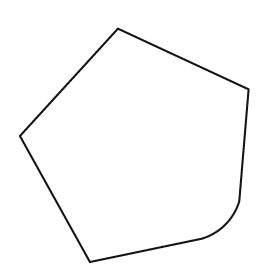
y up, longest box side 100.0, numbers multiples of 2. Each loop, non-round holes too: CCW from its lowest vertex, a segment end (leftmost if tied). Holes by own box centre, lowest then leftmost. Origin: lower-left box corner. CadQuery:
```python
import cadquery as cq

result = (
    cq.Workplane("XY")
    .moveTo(30.0, 0.0)
    .lineTo(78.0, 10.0)
    .threePointArc((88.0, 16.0), (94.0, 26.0))
    .lineTo(98.0, 74.0)
    .lineTo(42.0, 100.0)
    .lineTo(0.0, 54.0)
    .close()
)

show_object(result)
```